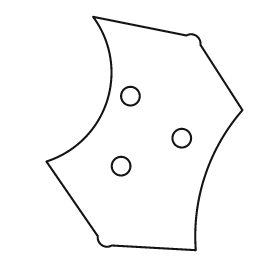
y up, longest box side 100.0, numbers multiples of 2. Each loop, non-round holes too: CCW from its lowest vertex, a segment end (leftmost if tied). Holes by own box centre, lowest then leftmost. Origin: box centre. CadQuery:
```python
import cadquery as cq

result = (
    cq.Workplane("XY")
    .moveTo(22.0, -50.0)
    .threePointArc((26.0, -18.0), (42.0, 10.0))
    .lineTo(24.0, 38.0)
    .threePointArc((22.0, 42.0), (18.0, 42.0))
    .lineTo(-22.0, 50.0)
    .threePointArc((-16.0, 14.0), (-42.0, -12.0))
    .lineTo(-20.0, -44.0)
    .threePointArc((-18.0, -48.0), (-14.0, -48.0))
    .close()
    .moveTo(-10.0, -14.0)
    .circle(4.0)
    .moveTo(16.0, -2.0)
    .circle(4.0)
    .moveTo(-6.0, 16.0)
    .circle(4.0)
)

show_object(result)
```